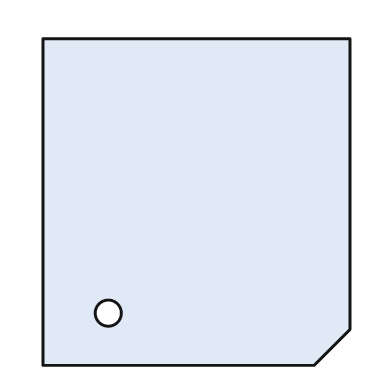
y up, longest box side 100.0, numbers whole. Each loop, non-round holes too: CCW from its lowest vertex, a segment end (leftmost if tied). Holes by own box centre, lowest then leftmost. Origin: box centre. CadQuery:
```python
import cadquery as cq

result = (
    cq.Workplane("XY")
    .moveTo(-47.0, -50.0)
    .lineTo(36.0, -50.0)
    .lineTo(47.0, -39.0)
    .lineTo(47.0, 50.0)
    .lineTo(-47.0, 50.0)
    .close()
    .moveTo(-27.0, -34.0)
    .circle(4.0)
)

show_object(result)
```